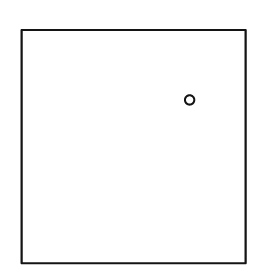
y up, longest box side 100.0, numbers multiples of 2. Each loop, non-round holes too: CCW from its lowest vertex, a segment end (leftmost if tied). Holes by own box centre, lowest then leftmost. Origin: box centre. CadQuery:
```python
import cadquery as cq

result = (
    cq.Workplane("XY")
    .moveTo(-48.0, -50.0)
    .lineTo(48.0, -50.0)
    .lineTo(48.0, 50.0)
    .lineTo(-48.0, 50.0)
    .close()
    .moveTo(24.0, 20.0)
    .circle(2.0)
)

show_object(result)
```